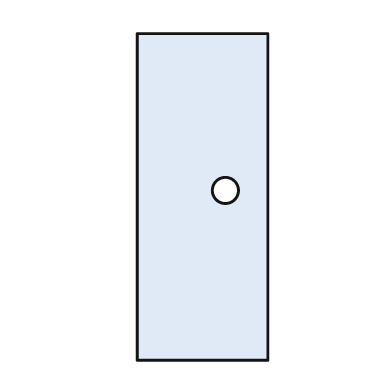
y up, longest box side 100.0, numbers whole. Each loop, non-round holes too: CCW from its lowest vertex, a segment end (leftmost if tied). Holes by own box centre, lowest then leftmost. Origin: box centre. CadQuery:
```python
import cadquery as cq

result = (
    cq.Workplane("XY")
    .moveTo(-20.0, -50.0)
    .lineTo(20.0, -50.0)
    .lineTo(20.0, 50.0)
    .lineTo(-20.0, 50.0)
    .close()
    .moveTo(7.0, 2.0)
    .circle(4.0)
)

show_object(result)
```